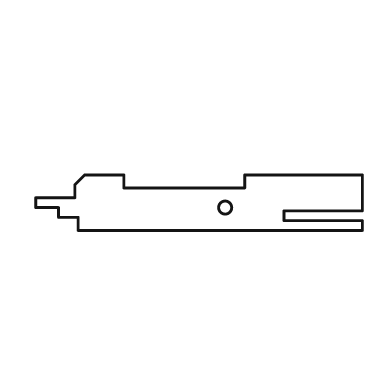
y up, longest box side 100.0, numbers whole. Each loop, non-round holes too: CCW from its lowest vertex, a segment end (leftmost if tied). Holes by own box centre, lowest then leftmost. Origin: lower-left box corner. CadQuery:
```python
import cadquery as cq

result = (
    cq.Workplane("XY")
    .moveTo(13.0, 0.0)
    .lineTo(100.0, 0.0)
    .lineTo(100.0, 3.0)
    .lineTo(76.0, 3.0)
    .lineTo(76.0, 6.0)
    .lineTo(100.0, 6.0)
    .lineTo(100.0, 17.0)
    .lineTo(64.0, 17.0)
    .lineTo(64.0, 13.0)
    .lineTo(27.0, 13.0)
    .lineTo(27.0, 17.0)
    .lineTo(15.0, 17.0)
    .lineTo(12.0, 14.0)
    .lineTo(12.0, 10.0)
    .lineTo(0.0, 10.0)
    .lineTo(0.0, 7.0)
    .lineTo(7.0, 7.0)
    .lineTo(7.0, 4.0)
    .lineTo(13.0, 4.0)
    .close()
    .moveTo(58.0, 7.0)
    .circle(2.0)
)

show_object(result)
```